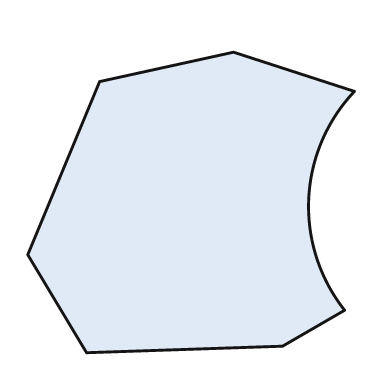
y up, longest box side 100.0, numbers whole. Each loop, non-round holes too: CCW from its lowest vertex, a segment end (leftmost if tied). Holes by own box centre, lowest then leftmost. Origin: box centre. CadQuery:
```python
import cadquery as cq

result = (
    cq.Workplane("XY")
    .moveTo(-32.0, -46.0)
    .lineTo(28.0, -44.0)
    .lineTo(47.0, -33.0)
    .threePointArc((36.0, 1.0), (50.0, 34.0))
    .lineTo(13.0, 46.0)
    .lineTo(-28.0, 37.0)
    .lineTo(-50.0, -16.0)
    .close()
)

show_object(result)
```